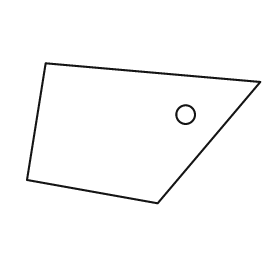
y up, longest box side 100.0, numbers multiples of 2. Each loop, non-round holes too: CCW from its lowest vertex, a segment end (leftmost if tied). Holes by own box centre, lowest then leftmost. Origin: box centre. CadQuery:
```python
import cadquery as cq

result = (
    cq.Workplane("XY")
    .moveTo(6.0, -30.0)
    .lineTo(50.0, 22.0)
    .lineTo(-42.0, 30.0)
    .lineTo(-50.0, -20.0)
    .close()
    .moveTo(18.0, 8.0)
    .circle(4.0)
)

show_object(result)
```